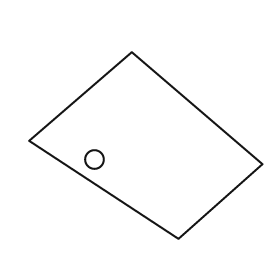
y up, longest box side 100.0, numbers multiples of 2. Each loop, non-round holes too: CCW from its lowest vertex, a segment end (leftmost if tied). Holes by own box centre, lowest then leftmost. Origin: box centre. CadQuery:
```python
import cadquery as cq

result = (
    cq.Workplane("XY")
    .moveTo(14.0, -40.0)
    .lineTo(50.0, -8.0)
    .lineTo(-6.0, 40.0)
    .lineTo(-50.0, 2.0)
    .close()
    .moveTo(-22.0, -6.0)
    .circle(4.0)
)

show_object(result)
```